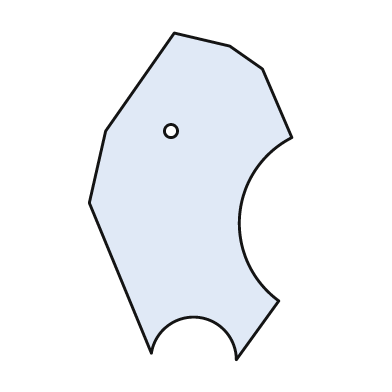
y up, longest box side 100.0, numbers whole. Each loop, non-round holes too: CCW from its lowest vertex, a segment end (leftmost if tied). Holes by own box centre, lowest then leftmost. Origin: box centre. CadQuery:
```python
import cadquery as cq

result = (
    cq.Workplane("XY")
    .moveTo(14.0, -50.0)
    .lineTo(27.0, -32.0)
    .threePointArc((15.0, -6.0), (31.0, 18.0))
    .lineTo(22.0, 39.0)
    .lineTo(12.0, 46.0)
    .lineTo(-5.0, 50.0)
    .lineTo(-26.0, 20.0)
    .lineTo(-31.0, -2.0)
    .lineTo(-12.0, -48.0)
    .threePointArc((2.0, -37.0), (14.0, -50.0))
    .close()
    .moveTo(-6.0, 20.0)
    .circle(2.0)
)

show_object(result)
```